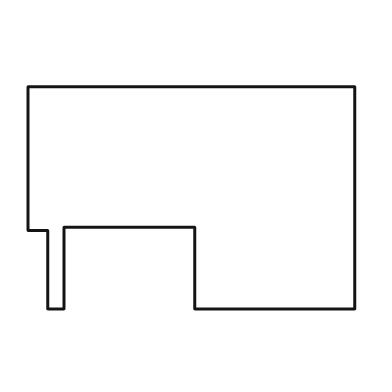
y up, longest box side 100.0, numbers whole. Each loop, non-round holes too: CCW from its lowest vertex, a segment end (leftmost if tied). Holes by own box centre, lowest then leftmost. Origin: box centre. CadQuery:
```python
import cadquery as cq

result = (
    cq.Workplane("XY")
    .moveTo(-44.0, -34.0)
    .lineTo(-39.0, -34.0)
    .lineTo(-39.0, -9.0)
    .lineTo(1.0, -9.0)
    .lineTo(1.0, -34.0)
    .lineTo(50.0, -34.0)
    .lineTo(50.0, 34.0)
    .lineTo(-50.0, 34.0)
    .lineTo(-50.0, -10.0)
    .lineTo(-44.0, -10.0)
    .close()
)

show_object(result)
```